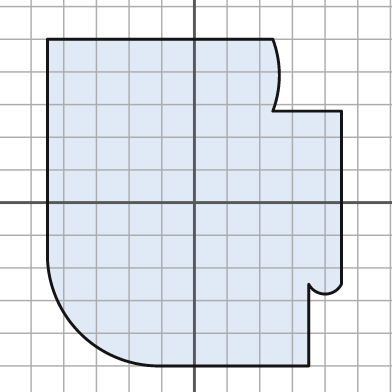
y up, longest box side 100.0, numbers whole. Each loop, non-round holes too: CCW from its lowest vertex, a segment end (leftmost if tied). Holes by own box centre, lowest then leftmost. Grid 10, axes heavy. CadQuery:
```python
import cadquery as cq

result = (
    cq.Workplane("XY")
    .moveTo(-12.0, -50.0)
    .lineTo(35.0, -50.0)
    .lineTo(35.0, -25.0)
    .threePointArc((40.0, -28.0), (45.0, -25.0))
    .lineTo(45.0, 28.0)
    .lineTo(24.0, 28.0)
    .threePointArc((26.0, 39.0), (24.0, 50.0))
    .lineTo(-45.0, 50.0)
    .lineTo(-45.0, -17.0)
    .threePointArc((-35.0, -40.0), (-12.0, -50.0))
    .close()
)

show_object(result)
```